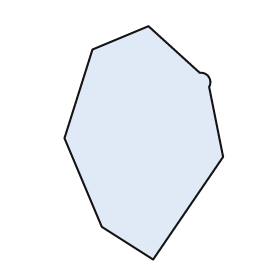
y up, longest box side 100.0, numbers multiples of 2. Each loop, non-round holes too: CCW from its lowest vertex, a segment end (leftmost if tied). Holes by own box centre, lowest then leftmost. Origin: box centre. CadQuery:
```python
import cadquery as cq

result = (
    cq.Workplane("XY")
    .moveTo(4.0, -50.0)
    .lineTo(34.0, -6.0)
    .lineTo(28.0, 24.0)
    .threePointArc((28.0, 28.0), (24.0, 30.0))
    .lineTo(2.0, 50.0)
    .lineTo(-22.0, 40.0)
    .lineTo(-34.0, 2.0)
    .lineTo(-18.0, -36.0)
    .close()
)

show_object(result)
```